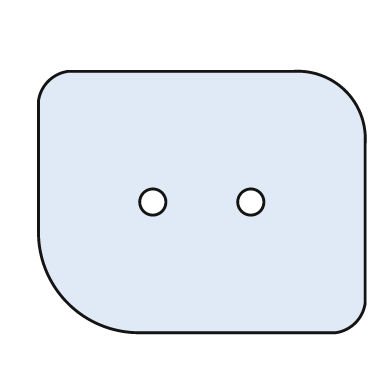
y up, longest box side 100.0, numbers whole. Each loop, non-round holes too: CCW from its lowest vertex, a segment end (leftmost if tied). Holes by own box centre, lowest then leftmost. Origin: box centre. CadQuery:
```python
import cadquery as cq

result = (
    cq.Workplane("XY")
    .moveTo(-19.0, -40.0)
    .lineTo(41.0, -40.0)
    .threePointArc((47.0, -37.0), (50.0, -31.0))
    .lineTo(50.0, 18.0)
    .threePointArc((44.0, 34.0), (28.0, 40.0))
    .lineTo(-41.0, 40.0)
    .threePointArc((-47.0, 37.0), (-50.0, 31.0))
    .lineTo(-50.0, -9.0)
    .threePointArc((-41.0, -31.0), (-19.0, -40.0))
    .close()
    .moveTo(-15.0, 0.0)
    .circle(4.0)
    .moveTo(15.0, 0.0)
    .circle(4.0)
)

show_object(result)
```